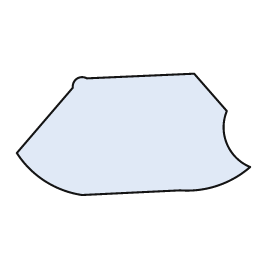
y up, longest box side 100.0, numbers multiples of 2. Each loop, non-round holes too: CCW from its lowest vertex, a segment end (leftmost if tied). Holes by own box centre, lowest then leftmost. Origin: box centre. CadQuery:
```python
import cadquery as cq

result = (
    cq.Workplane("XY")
    .moveTo(-22.0, -26.0)
    .lineTo(20.0, -24.0)
    .threePointArc((36.0, -22.0), (50.0, -14.0))
    .threePointArc((40.0, -4.0), (40.0, 10.0))
    .lineTo(26.0, 26.0)
    .lineTo(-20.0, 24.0)
    .threePointArc((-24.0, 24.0), (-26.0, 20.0))
    .lineTo(-50.0, -8.0)
    .threePointArc((-38.0, -20.0), (-22.0, -26.0))
    .close()
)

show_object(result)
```